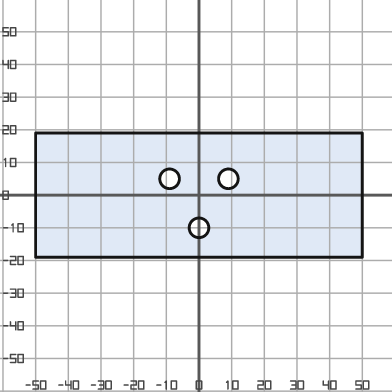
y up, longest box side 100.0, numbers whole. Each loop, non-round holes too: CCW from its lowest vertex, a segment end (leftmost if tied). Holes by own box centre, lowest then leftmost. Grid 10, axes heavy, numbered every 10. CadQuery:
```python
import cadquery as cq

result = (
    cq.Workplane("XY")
    .moveTo(-50.0, -19.0)
    .lineTo(50.0, -19.0)
    .lineTo(50.0, 19.0)
    .lineTo(-50.0, 19.0)
    .close()
    .moveTo(0.0, -10.0)
    .circle(3.0)
    .moveTo(-9.0, 5.0)
    .circle(3.0)
    .moveTo(9.0, 5.0)
    .circle(3.0)
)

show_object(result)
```